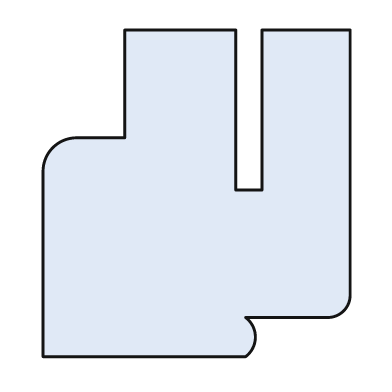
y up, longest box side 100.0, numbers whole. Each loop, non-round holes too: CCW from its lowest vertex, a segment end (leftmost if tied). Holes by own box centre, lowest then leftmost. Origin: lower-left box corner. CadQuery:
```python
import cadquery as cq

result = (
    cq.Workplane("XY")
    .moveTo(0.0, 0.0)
    .lineTo(62.0, 0.0)
    .threePointArc((65.0, 6.0), (62.0, 12.0))
    .lineTo(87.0, 12.0)
    .threePointArc((92.0, 14.0), (94.0, 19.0))
    .lineTo(94.0, 100.0)
    .lineTo(67.0, 100.0)
    .lineTo(67.0, 51.0)
    .lineTo(59.0, 51.0)
    .lineTo(59.0, 100.0)
    .lineTo(25.0, 100.0)
    .lineTo(25.0, 67.0)
    .lineTo(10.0, 67.0)
    .threePointArc((3.0, 64.0), (0.0, 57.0))
    .close()
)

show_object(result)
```